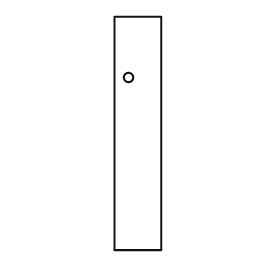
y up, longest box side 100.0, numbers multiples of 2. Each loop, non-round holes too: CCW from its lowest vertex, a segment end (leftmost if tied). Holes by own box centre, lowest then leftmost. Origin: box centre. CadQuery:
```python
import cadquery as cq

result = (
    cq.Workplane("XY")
    .moveTo(-10.0, -50.0)
    .lineTo(10.0, -50.0)
    .lineTo(10.0, 50.0)
    .lineTo(-10.0, 50.0)
    .close()
    .moveTo(-4.0, 24.0)
    .circle(2.0)
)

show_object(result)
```